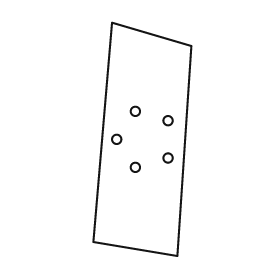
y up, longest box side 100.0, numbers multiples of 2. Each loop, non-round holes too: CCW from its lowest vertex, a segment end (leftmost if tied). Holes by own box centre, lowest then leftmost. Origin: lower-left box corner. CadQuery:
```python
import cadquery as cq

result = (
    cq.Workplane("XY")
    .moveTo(36.0, 0.0)
    .lineTo(42.0, 90.0)
    .lineTo(8.0, 100.0)
    .lineTo(0.0, 6.0)
    .close()
    .moveTo(18.0, 38.0)
    .circle(2.0)
    .moveTo(32.0, 42.0)
    .circle(2.0)
    .moveTo(10.0, 50.0)
    .circle(2.0)
    .moveTo(32.0, 58.0)
    .circle(2.0)
    .moveTo(18.0, 62.0)
    .circle(2.0)
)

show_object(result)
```